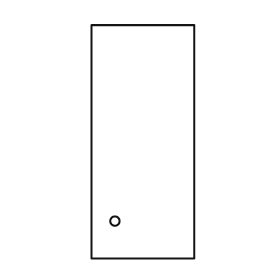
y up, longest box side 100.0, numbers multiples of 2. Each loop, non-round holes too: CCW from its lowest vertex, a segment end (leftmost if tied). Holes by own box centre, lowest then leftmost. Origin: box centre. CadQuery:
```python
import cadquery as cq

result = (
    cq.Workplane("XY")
    .moveTo(-22.0, -50.0)
    .lineTo(22.0, -50.0)
    .lineTo(22.0, 50.0)
    .lineTo(-22.0, 50.0)
    .close()
    .moveTo(-12.0, -34.0)
    .circle(2.0)
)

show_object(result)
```